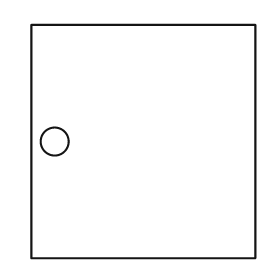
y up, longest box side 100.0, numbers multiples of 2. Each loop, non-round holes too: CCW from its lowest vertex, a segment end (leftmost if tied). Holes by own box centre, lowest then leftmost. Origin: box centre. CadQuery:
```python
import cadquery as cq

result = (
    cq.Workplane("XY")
    .moveTo(-48.0, -50.0)
    .lineTo(48.0, -50.0)
    .lineTo(48.0, 50.0)
    .lineTo(-48.0, 50.0)
    .close()
    .moveTo(-38.0, 0.0)
    .circle(6.0)
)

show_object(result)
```